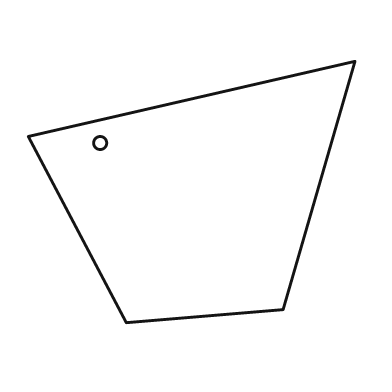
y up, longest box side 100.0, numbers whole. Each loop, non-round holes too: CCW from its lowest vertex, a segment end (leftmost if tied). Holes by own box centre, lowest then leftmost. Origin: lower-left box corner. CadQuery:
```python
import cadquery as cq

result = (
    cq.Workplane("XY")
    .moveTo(30.0, 0.0)
    .lineTo(78.0, 4.0)
    .lineTo(100.0, 80.0)
    .lineTo(0.0, 57.0)
    .close()
    .moveTo(22.0, 55.0)
    .circle(2.0)
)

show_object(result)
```